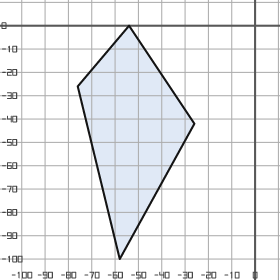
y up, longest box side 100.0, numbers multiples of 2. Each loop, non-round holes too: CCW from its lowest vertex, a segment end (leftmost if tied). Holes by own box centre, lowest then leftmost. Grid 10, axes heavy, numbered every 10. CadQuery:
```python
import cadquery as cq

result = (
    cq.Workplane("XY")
    .moveTo(-58.0, -100.0)
    .lineTo(-26.0, -42.0)
    .lineTo(-54.0, 0.0)
    .lineTo(-76.0, -26.0)
    .close()
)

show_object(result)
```